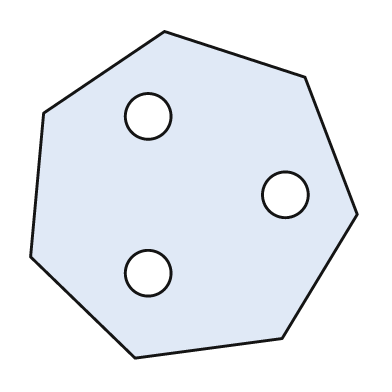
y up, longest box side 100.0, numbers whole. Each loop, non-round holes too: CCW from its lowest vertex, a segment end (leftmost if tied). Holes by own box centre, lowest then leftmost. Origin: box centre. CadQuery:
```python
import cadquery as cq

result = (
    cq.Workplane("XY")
    .moveTo(-18.0, -50.0)
    .lineTo(27.0, -44.0)
    .lineTo(50.0, -6.0)
    .lineTo(34.0, 36.0)
    .lineTo(-9.0, 50.0)
    .lineTo(-46.0, 25.0)
    .lineTo(-50.0, -19.0)
    .close()
    .moveTo(-14.0, -24.0)
    .circle(7.0)
    .moveTo(28.0, 0.0)
    .circle(7.0)
    .moveTo(-14.0, 24.0)
    .circle(7.0)
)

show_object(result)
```